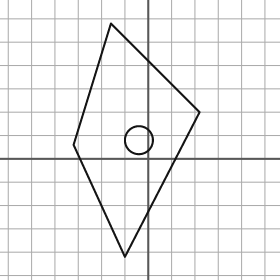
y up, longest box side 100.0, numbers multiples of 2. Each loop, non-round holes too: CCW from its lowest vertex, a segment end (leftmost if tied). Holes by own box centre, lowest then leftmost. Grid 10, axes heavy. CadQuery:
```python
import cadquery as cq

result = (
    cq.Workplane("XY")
    .moveTo(-10.0, -42.0)
    .lineTo(22.0, 20.0)
    .lineTo(-16.0, 58.0)
    .lineTo(-32.0, 6.0)
    .close()
    .moveTo(-4.0, 8.0)
    .circle(6.0)
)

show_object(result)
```